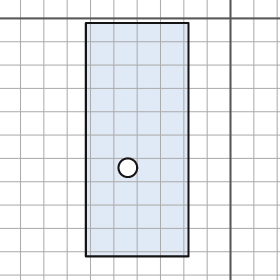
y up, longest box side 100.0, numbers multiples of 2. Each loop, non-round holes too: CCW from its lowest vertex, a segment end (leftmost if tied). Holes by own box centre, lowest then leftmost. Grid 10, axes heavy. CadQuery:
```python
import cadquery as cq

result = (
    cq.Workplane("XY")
    .moveTo(-62.0, -102.0)
    .lineTo(-18.0, -102.0)
    .lineTo(-18.0, -2.0)
    .lineTo(-62.0, -2.0)
    .close()
    .moveTo(-44.0, -64.0)
    .circle(4.0)
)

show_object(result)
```